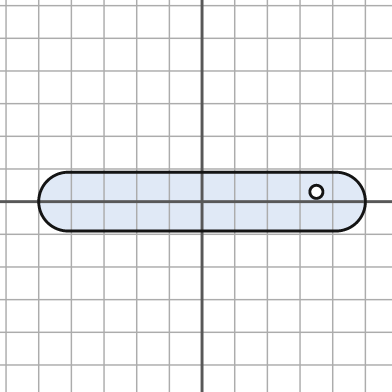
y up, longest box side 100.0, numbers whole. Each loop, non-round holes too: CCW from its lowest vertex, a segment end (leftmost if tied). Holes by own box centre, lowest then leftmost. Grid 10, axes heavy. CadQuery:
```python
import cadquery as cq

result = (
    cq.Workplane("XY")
    .moveTo(-41.0, -9.0)
    .lineTo(41.0, -9.0)
    .threePointArc((50.0, 0.0), (41.0, 9.0))
    .lineTo(-41.0, 9.0)
    .threePointArc((-50.0, 0.0), (-41.0, -9.0))
    .close()
    .moveTo(35.0, 3.0)
    .circle(2.0)
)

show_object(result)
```